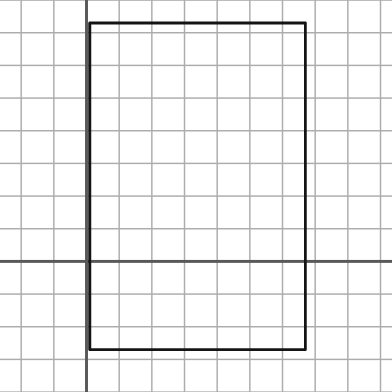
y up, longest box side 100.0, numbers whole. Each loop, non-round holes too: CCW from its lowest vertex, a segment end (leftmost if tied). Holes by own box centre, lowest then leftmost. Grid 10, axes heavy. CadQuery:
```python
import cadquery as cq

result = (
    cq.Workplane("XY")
    .moveTo(1.0, -27.0)
    .lineTo(67.0, -27.0)
    .lineTo(67.0, 73.0)
    .lineTo(1.0, 73.0)
    .close()
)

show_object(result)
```